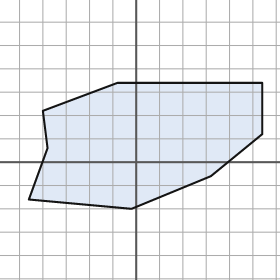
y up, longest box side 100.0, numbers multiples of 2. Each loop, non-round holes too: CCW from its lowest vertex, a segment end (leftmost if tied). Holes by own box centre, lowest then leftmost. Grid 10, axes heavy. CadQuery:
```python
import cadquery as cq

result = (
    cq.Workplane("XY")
    .moveTo(-2.0, -20.0)
    .lineTo(32.0, -6.0)
    .lineTo(54.0, 12.0)
    .lineTo(54.0, 34.0)
    .lineTo(-8.0, 34.0)
    .lineTo(-40.0, 22.0)
    .lineTo(-38.0, 6.0)
    .lineTo(-46.0, -16.0)
    .close()
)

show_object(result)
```